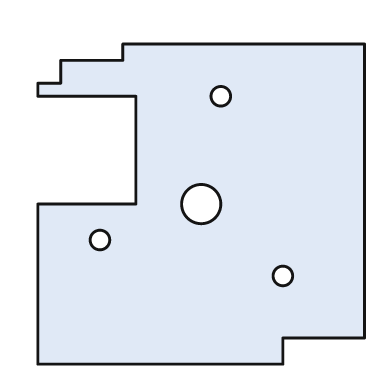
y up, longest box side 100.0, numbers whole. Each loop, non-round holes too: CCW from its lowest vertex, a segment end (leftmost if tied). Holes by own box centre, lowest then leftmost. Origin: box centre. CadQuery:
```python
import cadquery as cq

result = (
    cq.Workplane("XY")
    .moveTo(-50.0, -49.0)
    .lineTo(25.0, -49.0)
    .lineTo(25.0, -41.0)
    .lineTo(50.0, -41.0)
    .lineTo(50.0, 49.0)
    .lineTo(-24.0, 49.0)
    .lineTo(-24.0, 44.0)
    .lineTo(-43.0, 44.0)
    .lineTo(-43.0, 37.0)
    .lineTo(-50.0, 37.0)
    .lineTo(-50.0, 33.0)
    .lineTo(-20.0, 33.0)
    .lineTo(-20.0, 0.0)
    .lineTo(-50.0, 0.0)
    .close()
    .moveTo(25.0, -22.0)
    .circle(3.0)
    .moveTo(-31.0, -11.0)
    .circle(3.0)
    .moveTo(0.0, 0.0)
    .circle(6.0)
    .moveTo(6.0, 33.0)
    .circle(3.0)
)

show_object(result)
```